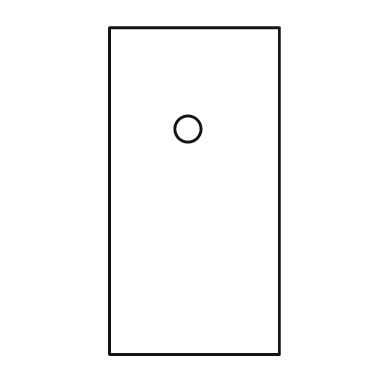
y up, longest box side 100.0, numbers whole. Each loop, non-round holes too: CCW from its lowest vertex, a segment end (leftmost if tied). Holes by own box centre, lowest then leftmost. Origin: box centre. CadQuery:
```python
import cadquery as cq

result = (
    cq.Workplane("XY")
    .moveTo(-26.0, -50.0)
    .lineTo(26.0, -50.0)
    .lineTo(26.0, 50.0)
    .lineTo(-26.0, 50.0)
    .close()
    .moveTo(-2.0, 19.0)
    .circle(4.0)
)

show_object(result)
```